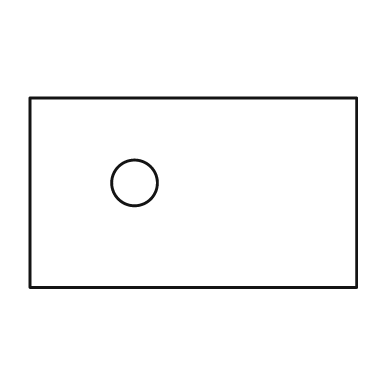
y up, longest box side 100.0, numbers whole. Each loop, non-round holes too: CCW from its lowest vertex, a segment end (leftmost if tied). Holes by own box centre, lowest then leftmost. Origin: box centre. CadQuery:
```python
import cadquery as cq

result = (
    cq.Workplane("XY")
    .moveTo(-50.0, -29.0)
    .lineTo(50.0, -29.0)
    .lineTo(50.0, 29.0)
    .lineTo(-50.0, 29.0)
    .close()
    .moveTo(-18.0, 3.0)
    .circle(7.0)
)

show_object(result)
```